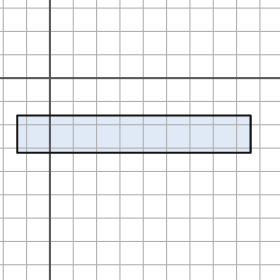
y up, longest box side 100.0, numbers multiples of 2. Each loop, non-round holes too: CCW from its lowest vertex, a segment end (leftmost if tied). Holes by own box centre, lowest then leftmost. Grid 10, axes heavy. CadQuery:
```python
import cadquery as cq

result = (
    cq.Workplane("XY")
    .moveTo(-14.0, -32.0)
    .lineTo(86.0, -32.0)
    .lineTo(86.0, -16.0)
    .lineTo(-14.0, -16.0)
    .close()
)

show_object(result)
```